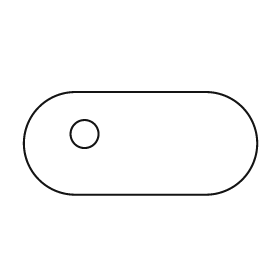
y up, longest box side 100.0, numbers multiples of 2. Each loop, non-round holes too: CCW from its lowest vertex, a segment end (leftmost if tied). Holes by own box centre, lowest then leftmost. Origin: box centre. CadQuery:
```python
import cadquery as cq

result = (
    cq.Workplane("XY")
    .moveTo(-28.0, -22.0)
    .lineTo(28.0, -22.0)
    .threePointArc((50.0, 0.0), (28.0, 22.0))
    .lineTo(-28.0, 22.0)
    .threePointArc((-50.0, 0.0), (-28.0, -22.0))
    .close()
    .moveTo(-24.0, 4.0)
    .circle(6.0)
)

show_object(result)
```